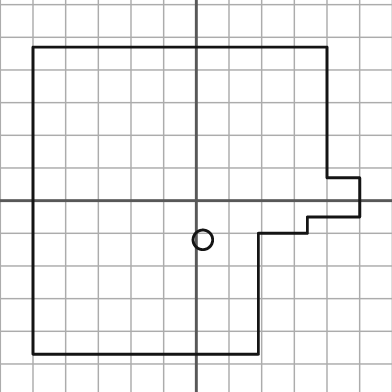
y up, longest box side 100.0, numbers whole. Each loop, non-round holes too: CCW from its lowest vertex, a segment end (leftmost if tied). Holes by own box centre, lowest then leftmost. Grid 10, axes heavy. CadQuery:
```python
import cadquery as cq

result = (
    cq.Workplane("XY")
    .moveTo(-50.0, -47.0)
    .lineTo(19.0, -47.0)
    .lineTo(19.0, -10.0)
    .lineTo(34.0, -10.0)
    .lineTo(34.0, -5.0)
    .lineTo(50.0, -5.0)
    .lineTo(50.0, 7.0)
    .lineTo(40.0, 7.0)
    .lineTo(40.0, 47.0)
    .lineTo(-50.0, 47.0)
    .close()
    .moveTo(2.0, -12.0)
    .circle(3.0)
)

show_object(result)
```